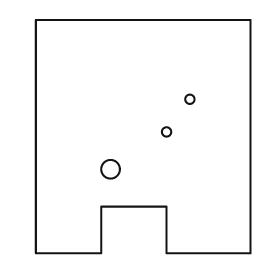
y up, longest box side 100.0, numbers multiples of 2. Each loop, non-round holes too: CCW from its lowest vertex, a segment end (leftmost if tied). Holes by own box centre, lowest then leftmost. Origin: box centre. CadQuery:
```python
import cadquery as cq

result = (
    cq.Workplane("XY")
    .moveTo(-46.0, -50.0)
    .lineTo(-18.0, -50.0)
    .lineTo(-18.0, -30.0)
    .lineTo(10.0, -30.0)
    .lineTo(10.0, -50.0)
    .lineTo(46.0, -50.0)
    .lineTo(46.0, 50.0)
    .lineTo(-46.0, 50.0)
    .close()
    .moveTo(-14.0, -14.0)
    .circle(4.0)
    .moveTo(10.0, 2.0)
    .circle(2.0)
    .moveTo(20.0, 16.0)
    .circle(2.0)
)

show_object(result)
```